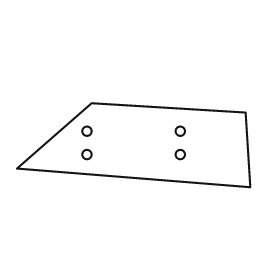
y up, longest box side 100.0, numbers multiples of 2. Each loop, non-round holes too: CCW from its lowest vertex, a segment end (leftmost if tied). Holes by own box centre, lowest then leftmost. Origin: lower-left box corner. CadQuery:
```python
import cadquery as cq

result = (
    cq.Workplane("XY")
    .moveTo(100.0, 0.0)
    .lineTo(98.0, 32.0)
    .lineTo(32.0, 36.0)
    .lineTo(0.0, 8.0)
    .close()
    .moveTo(30.0, 14.0)
    .circle(2.0)
    .moveTo(70.0, 14.0)
    .circle(2.0)
    .moveTo(30.0, 24.0)
    .circle(2.0)
    .moveTo(70.0, 24.0)
    .circle(2.0)
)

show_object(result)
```